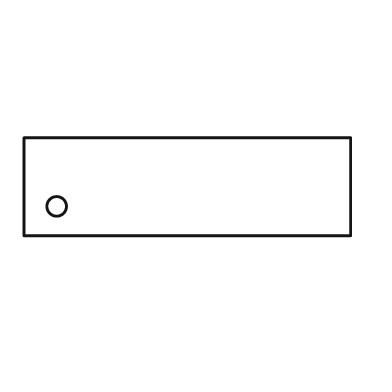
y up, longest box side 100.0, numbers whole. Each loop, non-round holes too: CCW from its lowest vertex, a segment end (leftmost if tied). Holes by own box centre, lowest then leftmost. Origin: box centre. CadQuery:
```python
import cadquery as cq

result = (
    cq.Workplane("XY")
    .moveTo(-50.0, -15.0)
    .lineTo(50.0, -15.0)
    .lineTo(50.0, 15.0)
    .lineTo(-50.0, 15.0)
    .close()
    .moveTo(-40.0, -6.0)
    .circle(3.0)
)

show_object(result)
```